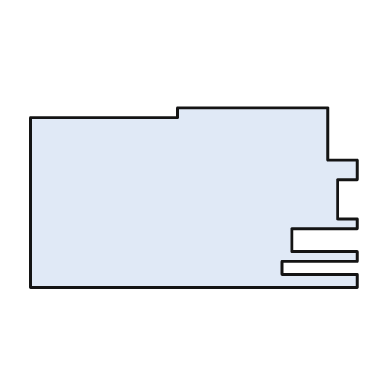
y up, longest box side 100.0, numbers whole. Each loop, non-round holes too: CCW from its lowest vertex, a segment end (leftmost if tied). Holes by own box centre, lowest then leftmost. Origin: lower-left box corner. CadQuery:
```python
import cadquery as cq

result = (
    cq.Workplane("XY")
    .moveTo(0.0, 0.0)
    .lineTo(100.0, 0.0)
    .lineTo(100.0, 4.0)
    .lineTo(77.0, 4.0)
    .lineTo(77.0, 8.0)
    .lineTo(100.0, 8.0)
    .lineTo(100.0, 11.0)
    .lineTo(80.0, 11.0)
    .lineTo(80.0, 18.0)
    .lineTo(100.0, 18.0)
    .lineTo(100.0, 21.0)
    .lineTo(94.0, 21.0)
    .lineTo(94.0, 33.0)
    .lineTo(100.0, 33.0)
    .lineTo(100.0, 39.0)
    .lineTo(91.0, 39.0)
    .lineTo(91.0, 55.0)
    .lineTo(45.0, 55.0)
    .lineTo(45.0, 52.0)
    .lineTo(0.0, 52.0)
    .close()
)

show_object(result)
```